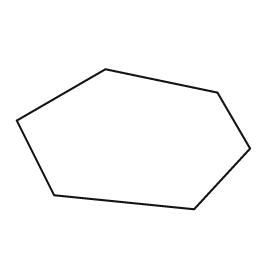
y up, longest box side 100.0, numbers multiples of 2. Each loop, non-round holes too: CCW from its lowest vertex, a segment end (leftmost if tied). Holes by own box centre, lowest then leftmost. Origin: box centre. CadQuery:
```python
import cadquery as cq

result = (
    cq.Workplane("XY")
    .moveTo(26.0, -30.0)
    .lineTo(50.0, -4.0)
    .lineTo(36.0, 20.0)
    .lineTo(-12.0, 30.0)
    .lineTo(-50.0, 8.0)
    .lineTo(-34.0, -24.0)
    .close()
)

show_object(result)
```